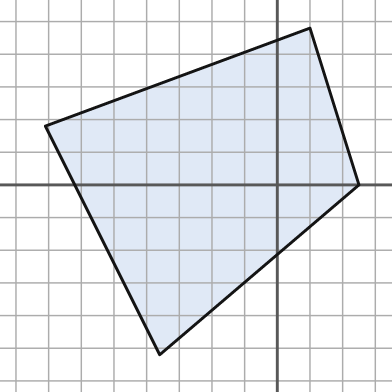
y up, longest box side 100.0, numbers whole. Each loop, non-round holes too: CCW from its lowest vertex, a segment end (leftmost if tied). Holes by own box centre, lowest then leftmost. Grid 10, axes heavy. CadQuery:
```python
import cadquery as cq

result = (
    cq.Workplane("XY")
    .moveTo(-36.0, -52.0)
    .lineTo(25.0, 0.0)
    .lineTo(10.0, 48.0)
    .lineTo(-71.0, 18.0)
    .close()
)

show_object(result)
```